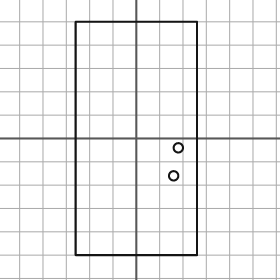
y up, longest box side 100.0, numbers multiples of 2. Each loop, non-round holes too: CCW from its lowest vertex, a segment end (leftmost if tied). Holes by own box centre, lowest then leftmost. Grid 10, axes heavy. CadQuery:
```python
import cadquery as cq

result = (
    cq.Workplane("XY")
    .moveTo(-26.0, -50.0)
    .lineTo(26.0, -50.0)
    .lineTo(26.0, 50.0)
    .lineTo(-26.0, 50.0)
    .close()
    .moveTo(16.0, -16.0)
    .circle(2.0)
    .moveTo(18.0, -4.0)
    .circle(2.0)
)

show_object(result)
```